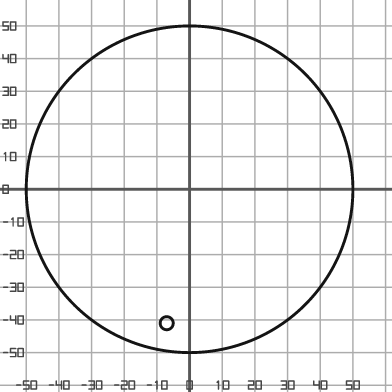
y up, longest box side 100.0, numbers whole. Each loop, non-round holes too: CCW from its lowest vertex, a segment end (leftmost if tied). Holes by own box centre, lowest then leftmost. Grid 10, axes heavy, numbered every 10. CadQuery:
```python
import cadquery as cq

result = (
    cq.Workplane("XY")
    .moveTo(0.0, 0.0)
    .circle(50.0)
    .moveTo(-7.0, -41.0)
    .circle(2.0)
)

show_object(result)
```